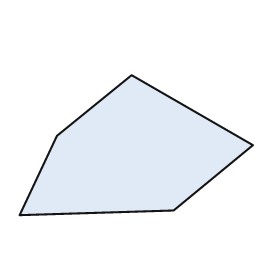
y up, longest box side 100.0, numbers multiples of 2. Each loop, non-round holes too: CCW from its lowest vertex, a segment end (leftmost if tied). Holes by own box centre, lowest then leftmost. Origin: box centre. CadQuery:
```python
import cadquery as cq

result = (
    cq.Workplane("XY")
    .moveTo(-50.0, -30.0)
    .lineTo(16.0, -28.0)
    .lineTo(50.0, 0.0)
    .lineTo(-2.0, 30.0)
    .lineTo(-34.0, 4.0)
    .close()
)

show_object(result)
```